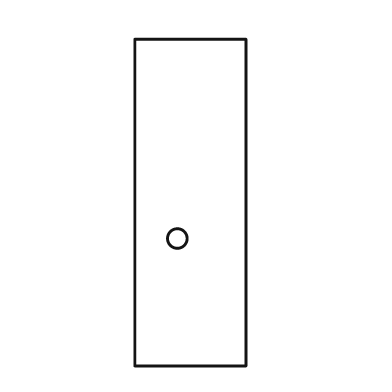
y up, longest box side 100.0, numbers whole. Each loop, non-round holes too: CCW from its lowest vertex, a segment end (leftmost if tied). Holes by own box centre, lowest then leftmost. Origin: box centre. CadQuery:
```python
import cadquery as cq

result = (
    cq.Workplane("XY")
    .moveTo(-17.0, -50.0)
    .lineTo(17.0, -50.0)
    .lineTo(17.0, 50.0)
    .lineTo(-17.0, 50.0)
    .close()
    .moveTo(-4.0, -11.0)
    .circle(3.0)
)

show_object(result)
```